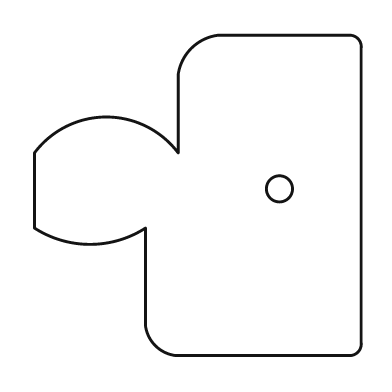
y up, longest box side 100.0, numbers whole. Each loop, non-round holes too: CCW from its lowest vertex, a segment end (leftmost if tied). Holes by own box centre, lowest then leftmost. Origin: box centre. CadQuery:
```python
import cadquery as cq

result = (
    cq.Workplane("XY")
    .moveTo(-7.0, -49.0)
    .lineTo(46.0, -49.0)
    .threePointArc((49.0, -48.0), (50.0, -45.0))
    .lineTo(50.0, 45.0)
    .threePointArc((49.0, 48.0), (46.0, 49.0))
    .lineTo(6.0, 49.0)
    .threePointArc((-2.0, 45.0), (-6.0, 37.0))
    .lineTo(-6.0, 13.0)
    .threePointArc((-28.0, 24.0), (-50.0, 13.0))
    .lineTo(-50.0, -10.0)
    .threePointArc((-33.0, -15.0), (-16.0, -10.0))
    .lineTo(-16.0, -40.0)
    .threePointArc((-13.0, -46.0), (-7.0, -49.0))
    .close()
    .moveTo(25.0, 2.0)
    .circle(4.0)
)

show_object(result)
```